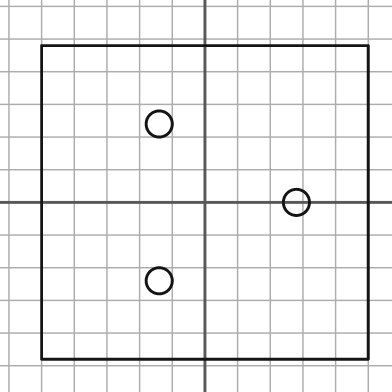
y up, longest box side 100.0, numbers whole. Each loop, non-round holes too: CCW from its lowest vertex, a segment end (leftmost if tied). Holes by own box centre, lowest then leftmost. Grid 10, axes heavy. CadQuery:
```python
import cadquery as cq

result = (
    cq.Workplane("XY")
    .moveTo(-50.0, -48.0)
    .lineTo(50.0, -48.0)
    .lineTo(50.0, 48.0)
    .lineTo(-50.0, 48.0)
    .close()
    .moveTo(-14.0, -24.0)
    .circle(4.0)
    .moveTo(28.0, 0.0)
    .circle(4.0)
    .moveTo(-14.0, 24.0)
    .circle(4.0)
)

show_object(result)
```